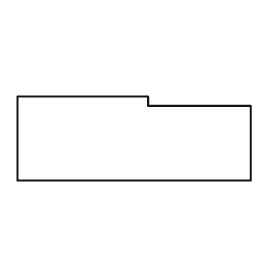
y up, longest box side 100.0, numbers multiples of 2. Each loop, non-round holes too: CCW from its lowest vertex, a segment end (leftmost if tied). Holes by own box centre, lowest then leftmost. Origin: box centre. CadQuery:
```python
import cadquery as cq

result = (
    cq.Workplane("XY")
    .moveTo(-50.0, -18.0)
    .lineTo(50.0, -18.0)
    .lineTo(50.0, 14.0)
    .lineTo(6.0, 14.0)
    .lineTo(6.0, 18.0)
    .lineTo(-50.0, 18.0)
    .close()
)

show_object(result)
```